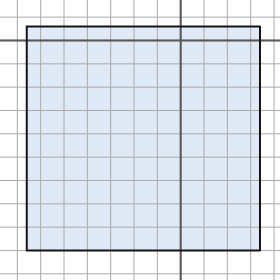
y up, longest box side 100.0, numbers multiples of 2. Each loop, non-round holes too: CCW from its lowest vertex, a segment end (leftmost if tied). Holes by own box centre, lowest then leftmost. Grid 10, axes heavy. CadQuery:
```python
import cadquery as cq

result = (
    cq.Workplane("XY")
    .moveTo(-66.0, -90.0)
    .lineTo(34.0, -90.0)
    .lineTo(34.0, 6.0)
    .lineTo(-66.0, 6.0)
    .close()
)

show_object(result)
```